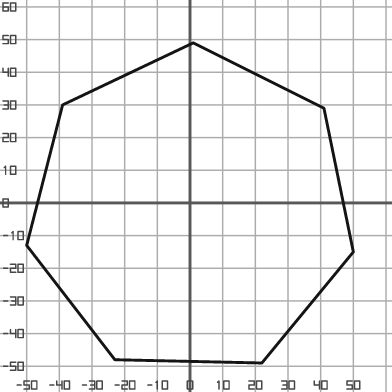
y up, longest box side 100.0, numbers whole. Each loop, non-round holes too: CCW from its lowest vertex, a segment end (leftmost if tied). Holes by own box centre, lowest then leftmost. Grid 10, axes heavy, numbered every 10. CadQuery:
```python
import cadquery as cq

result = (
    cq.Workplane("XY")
    .moveTo(22.0, -49.0)
    .lineTo(50.0, -15.0)
    .lineTo(41.0, 29.0)
    .lineTo(1.0, 49.0)
    .lineTo(-39.0, 30.0)
    .lineTo(-50.0, -13.0)
    .lineTo(-23.0, -48.0)
    .close()
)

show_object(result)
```